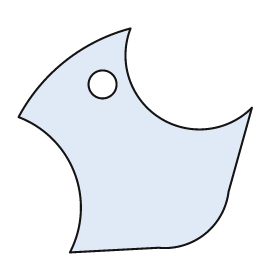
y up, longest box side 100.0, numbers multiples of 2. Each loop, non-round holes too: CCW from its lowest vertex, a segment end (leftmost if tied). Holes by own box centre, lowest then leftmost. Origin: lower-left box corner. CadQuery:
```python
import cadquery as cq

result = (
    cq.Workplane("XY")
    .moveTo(22.0, 0.0)
    .lineTo(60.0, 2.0)
    .threePointArc((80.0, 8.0), (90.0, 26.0))
    .lineTo(100.0, 62.0)
    .threePointArc((60.0, 58.0), (48.0, 96.0))
    .threePointArc((20.0, 82.0), (0.0, 58.0))
    .threePointArc((24.0, 34.0), (22.0, 0.0))
    .close()
    .moveTo(36.0, 72.0)
    .circle(6.0)
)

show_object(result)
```